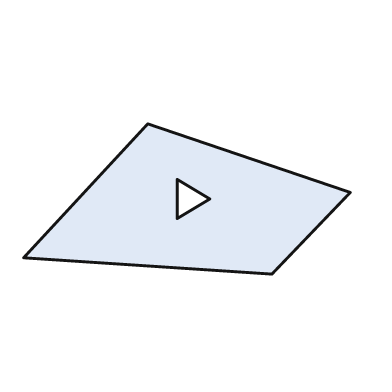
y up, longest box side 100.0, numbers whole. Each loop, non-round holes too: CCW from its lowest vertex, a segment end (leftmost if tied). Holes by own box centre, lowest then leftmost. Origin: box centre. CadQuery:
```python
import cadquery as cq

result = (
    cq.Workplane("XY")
    .moveTo(26.0, -23.0)
    .lineTo(50.0, 2.0)
    .lineTo(-12.0, 23.0)
    .lineTo(-50.0, -18.0)
    .close()
    .moveTo(-3.0, -6.0)
    .lineTo(7.0, 0.0)
    .lineTo(-3.0, 6.0)
    .close()
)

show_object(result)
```